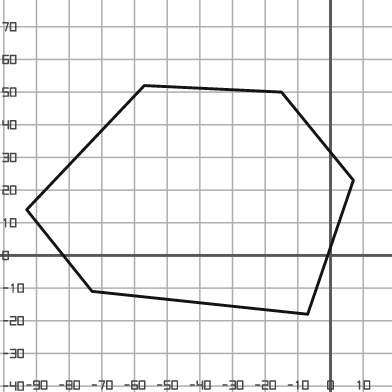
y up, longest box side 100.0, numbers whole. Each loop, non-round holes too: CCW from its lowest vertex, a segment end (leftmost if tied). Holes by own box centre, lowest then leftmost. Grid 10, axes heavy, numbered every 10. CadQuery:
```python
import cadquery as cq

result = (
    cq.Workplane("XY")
    .moveTo(-7.0, -18.0)
    .lineTo(7.0, 23.0)
    .lineTo(-15.0, 50.0)
    .lineTo(-57.0, 52.0)
    .lineTo(-93.0, 14.0)
    .lineTo(-73.0, -11.0)
    .close()
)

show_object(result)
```